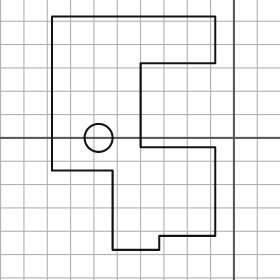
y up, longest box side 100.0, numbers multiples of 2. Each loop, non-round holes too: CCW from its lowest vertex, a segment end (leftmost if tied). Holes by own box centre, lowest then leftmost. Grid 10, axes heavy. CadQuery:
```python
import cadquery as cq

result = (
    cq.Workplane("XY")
    .moveTo(-52.0, -48.0)
    .lineTo(-32.0, -48.0)
    .lineTo(-32.0, -42.0)
    .lineTo(-8.0, -42.0)
    .lineTo(-8.0, -4.0)
    .lineTo(-40.0, -4.0)
    .lineTo(-40.0, 32.0)
    .lineTo(-8.0, 32.0)
    .lineTo(-8.0, 52.0)
    .lineTo(-78.0, 52.0)
    .lineTo(-78.0, -14.0)
    .lineTo(-52.0, -14.0)
    .close()
    .moveTo(-58.0, 0.0)
    .circle(6.0)
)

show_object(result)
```